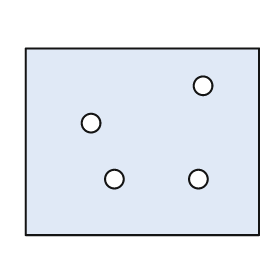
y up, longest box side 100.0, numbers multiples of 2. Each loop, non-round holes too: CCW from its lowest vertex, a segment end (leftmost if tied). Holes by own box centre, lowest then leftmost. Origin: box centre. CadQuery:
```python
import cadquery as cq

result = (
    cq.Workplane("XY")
    .moveTo(-50.0, -40.0)
    .lineTo(50.0, -40.0)
    .lineTo(50.0, 40.0)
    .lineTo(-50.0, 40.0)
    .close()
    .moveTo(-12.0, -16.0)
    .circle(4.0)
    .moveTo(24.0, -16.0)
    .circle(4.0)
    .moveTo(-22.0, 8.0)
    .circle(4.0)
    .moveTo(26.0, 24.0)
    .circle(4.0)
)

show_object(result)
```